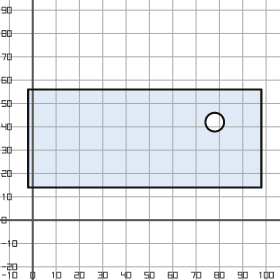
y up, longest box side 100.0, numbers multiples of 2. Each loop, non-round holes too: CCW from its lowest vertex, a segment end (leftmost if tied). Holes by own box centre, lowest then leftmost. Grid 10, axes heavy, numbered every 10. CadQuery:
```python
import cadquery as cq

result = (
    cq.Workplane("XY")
    .moveTo(-2.0, 14.0)
    .lineTo(98.0, 14.0)
    .lineTo(98.0, 56.0)
    .lineTo(-2.0, 56.0)
    .close()
    .moveTo(78.0, 42.0)
    .circle(4.0)
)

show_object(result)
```